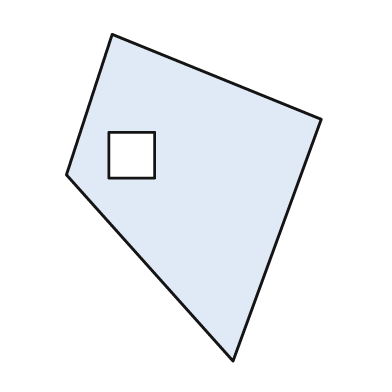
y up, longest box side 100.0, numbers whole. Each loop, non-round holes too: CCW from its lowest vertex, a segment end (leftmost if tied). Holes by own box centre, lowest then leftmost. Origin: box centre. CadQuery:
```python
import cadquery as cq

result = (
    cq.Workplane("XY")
    .moveTo(12.0, -50.0)
    .lineTo(39.0, 24.0)
    .lineTo(-25.0, 50.0)
    .lineTo(-39.0, 7.0)
    .close()
    .moveTo(-26.0, 6.0)
    .lineTo(-12.0, 6.0)
    .lineTo(-12.0, 20.0)
    .lineTo(-26.0, 20.0)
    .close()
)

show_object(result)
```